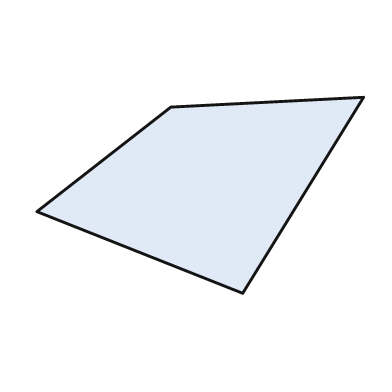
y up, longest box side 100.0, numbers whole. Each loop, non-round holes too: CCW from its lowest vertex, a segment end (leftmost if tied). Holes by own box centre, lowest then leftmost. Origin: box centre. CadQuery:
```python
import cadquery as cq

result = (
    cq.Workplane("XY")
    .moveTo(13.0, -30.0)
    .lineTo(50.0, 30.0)
    .lineTo(-9.0, 27.0)
    .lineTo(-50.0, -5.0)
    .close()
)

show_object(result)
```